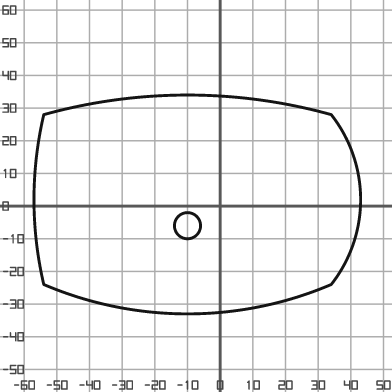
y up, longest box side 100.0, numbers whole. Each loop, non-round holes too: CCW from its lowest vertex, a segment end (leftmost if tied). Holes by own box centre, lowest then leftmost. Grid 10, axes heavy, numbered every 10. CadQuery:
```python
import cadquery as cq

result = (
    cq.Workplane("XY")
    .moveTo(-54.0, -24.0)
    .threePointArc((-10.0, -33.0), (34.0, -24.0))
    .threePointArc((43.0, 2.0), (34.0, 28.0))
    .threePointArc((-10.0, 34.0), (-54.0, 28.0))
    .threePointArc((-57.0, 2.0), (-54.0, -24.0))
    .close()
    .moveTo(-10.0, -6.0)
    .circle(4.0)
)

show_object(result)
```